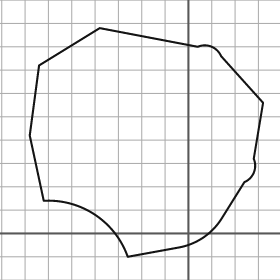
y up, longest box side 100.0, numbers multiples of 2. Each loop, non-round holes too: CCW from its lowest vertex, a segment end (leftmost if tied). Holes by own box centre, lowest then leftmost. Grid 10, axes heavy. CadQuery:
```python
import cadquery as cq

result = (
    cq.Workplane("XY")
    .moveTo(-26.0, -10.0)
    .lineTo(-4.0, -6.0)
    .threePointArc((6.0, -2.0), (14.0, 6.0))
    .lineTo(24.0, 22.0)
    .threePointArc((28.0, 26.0), (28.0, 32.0))
    .lineTo(32.0, 56.0)
    .lineTo(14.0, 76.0)
    .threePointArc((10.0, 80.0), (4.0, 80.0))
    .lineTo(-38.0, 88.0)
    .lineTo(-64.0, 72.0)
    .lineTo(-68.0, 42.0)
    .lineTo(-62.0, 14.0)
    .threePointArc((-40.0, 8.0), (-26.0, -10.0))
    .close()
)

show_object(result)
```